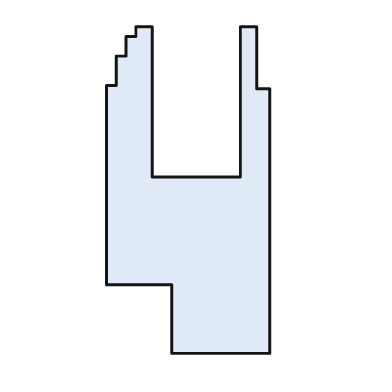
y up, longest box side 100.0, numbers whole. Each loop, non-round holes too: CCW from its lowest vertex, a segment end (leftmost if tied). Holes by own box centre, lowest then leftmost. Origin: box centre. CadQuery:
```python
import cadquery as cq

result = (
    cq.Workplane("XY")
    .moveTo(-5.0, -50.0)
    .lineTo(25.0, -50.0)
    .lineTo(25.0, 31.0)
    .lineTo(21.0, 31.0)
    .lineTo(21.0, 50.0)
    .lineTo(16.0, 50.0)
    .lineTo(16.0, 4.0)
    .lineTo(-11.0, 4.0)
    .lineTo(-11.0, 50.0)
    .lineTo(-16.0, 50.0)
    .lineTo(-16.0, 47.0)
    .lineTo(-19.0, 47.0)
    .lineTo(-19.0, 41.0)
    .lineTo(-22.0, 41.0)
    .lineTo(-22.0, 32.0)
    .lineTo(-25.0, 32.0)
    .lineTo(-25.0, -29.0)
    .lineTo(-5.0, -29.0)
    .close()
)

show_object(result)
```